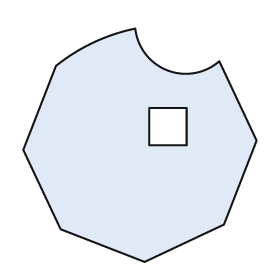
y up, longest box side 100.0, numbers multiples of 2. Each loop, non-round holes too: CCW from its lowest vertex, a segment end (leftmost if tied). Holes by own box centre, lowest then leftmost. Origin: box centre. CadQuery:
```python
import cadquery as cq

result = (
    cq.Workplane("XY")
    .moveTo(2.0, -50.0)
    .lineTo(36.0, -34.0)
    .lineTo(50.0, 2.0)
    .lineTo(34.0, 36.0)
    .threePointArc((12.0, 32.0), (-2.0, 50.0))
    .threePointArc((-20.0, 44.0), (-36.0, 34.0))
    .lineTo(-50.0, -2.0)
    .lineTo(-34.0, -36.0)
    .close()
    .moveTo(4.0, 0.0)
    .lineTo(20.0, 0.0)
    .lineTo(20.0, 16.0)
    .lineTo(4.0, 16.0)
    .close()
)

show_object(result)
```